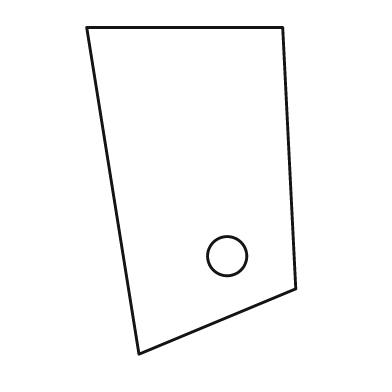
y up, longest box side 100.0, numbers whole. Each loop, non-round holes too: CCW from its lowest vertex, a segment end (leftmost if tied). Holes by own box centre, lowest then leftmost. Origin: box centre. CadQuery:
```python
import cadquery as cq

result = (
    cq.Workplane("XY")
    .moveTo(-16.0, -50.0)
    .lineTo(32.0, -30.0)
    .lineTo(28.0, 50.0)
    .lineTo(-32.0, 50.0)
    .close()
    .moveTo(11.0, -20.0)
    .circle(6.0)
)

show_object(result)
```